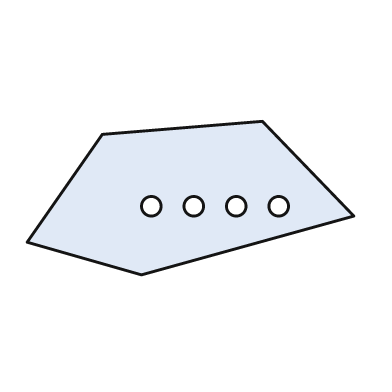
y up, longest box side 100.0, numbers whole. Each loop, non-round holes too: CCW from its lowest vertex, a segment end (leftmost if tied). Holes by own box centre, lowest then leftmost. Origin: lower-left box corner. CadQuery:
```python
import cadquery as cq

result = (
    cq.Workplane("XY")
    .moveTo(35.0, 0.0)
    .lineTo(100.0, 18.0)
    .lineTo(72.0, 47.0)
    .lineTo(23.0, 43.0)
    .lineTo(0.0, 10.0)
    .close()
    .moveTo(38.0, 21.0)
    .circle(3.0)
    .moveTo(51.0, 21.0)
    .circle(3.0)
    .moveTo(64.0, 21.0)
    .circle(3.0)
    .moveTo(77.0, 21.0)
    .circle(3.0)
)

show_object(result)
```